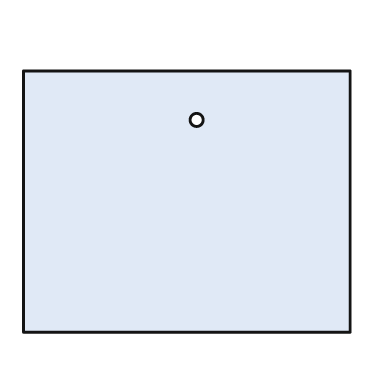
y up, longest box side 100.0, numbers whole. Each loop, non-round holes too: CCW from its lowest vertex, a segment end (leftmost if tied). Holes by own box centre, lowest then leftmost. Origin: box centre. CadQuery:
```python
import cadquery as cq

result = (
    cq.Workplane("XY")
    .moveTo(-50.0, -40.0)
    .lineTo(50.0, -40.0)
    .lineTo(50.0, 40.0)
    .lineTo(-50.0, 40.0)
    .close()
    .moveTo(3.0, 25.0)
    .circle(2.0)
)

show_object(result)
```